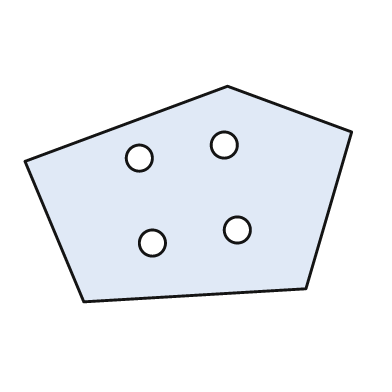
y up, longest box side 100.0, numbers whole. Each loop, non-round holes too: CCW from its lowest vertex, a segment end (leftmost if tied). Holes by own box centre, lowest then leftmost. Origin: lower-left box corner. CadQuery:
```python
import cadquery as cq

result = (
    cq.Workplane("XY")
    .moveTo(18.0, 0.0)
    .lineTo(86.0, 4.0)
    .lineTo(100.0, 52.0)
    .lineTo(62.0, 66.0)
    .lineTo(0.0, 43.0)
    .close()
    .moveTo(39.0, 18.0)
    .circle(4.0)
    .moveTo(65.0, 22.0)
    .circle(4.0)
    .moveTo(35.0, 44.0)
    .circle(4.0)
    .moveTo(61.0, 48.0)
    .circle(4.0)
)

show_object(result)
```